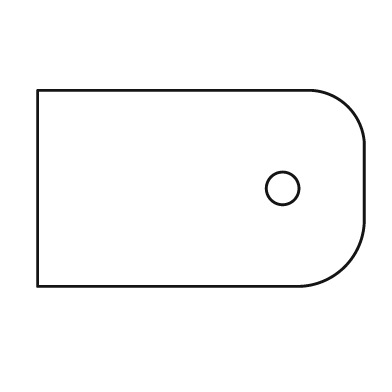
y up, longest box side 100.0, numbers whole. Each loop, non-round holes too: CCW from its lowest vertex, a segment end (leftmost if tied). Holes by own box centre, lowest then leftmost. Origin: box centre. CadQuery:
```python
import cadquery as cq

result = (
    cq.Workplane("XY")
    .moveTo(-50.0, -30.0)
    .lineTo(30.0, -30.0)
    .threePointArc((44.0, -24.0), (50.0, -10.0))
    .lineTo(50.0, 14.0)
    .threePointArc((45.0, 25.0), (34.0, 30.0))
    .lineTo(-50.0, 30.0)
    .close()
    .moveTo(25.0, 0.0)
    .circle(5.0)
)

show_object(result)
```